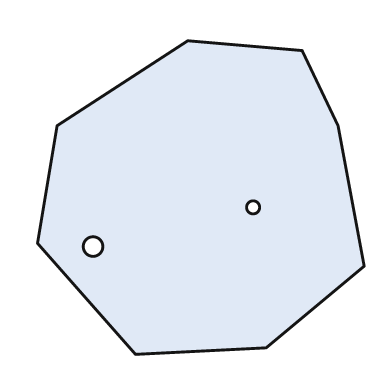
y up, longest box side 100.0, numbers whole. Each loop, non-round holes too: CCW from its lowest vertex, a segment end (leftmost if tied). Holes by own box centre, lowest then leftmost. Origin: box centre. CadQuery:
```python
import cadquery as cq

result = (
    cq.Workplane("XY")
    .moveTo(-20.0, -48.0)
    .lineTo(20.0, -46.0)
    .lineTo(50.0, -21.0)
    .lineTo(42.0, 22.0)
    .lineTo(31.0, 45.0)
    .lineTo(-4.0, 48.0)
    .lineTo(-44.0, 22.0)
    .lineTo(-50.0, -14.0)
    .close()
    .moveTo(-33.0, -15.0)
    .circle(3.0)
    .moveTo(16.0, -3.0)
    .circle(2.0)
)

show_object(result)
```